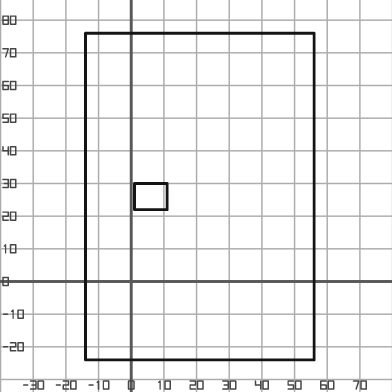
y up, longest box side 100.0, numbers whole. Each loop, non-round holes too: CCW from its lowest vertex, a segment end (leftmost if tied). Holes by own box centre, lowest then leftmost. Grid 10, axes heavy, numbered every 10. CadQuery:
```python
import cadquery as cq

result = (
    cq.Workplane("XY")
    .moveTo(-14.0, -24.0)
    .lineTo(56.0, -24.0)
    .lineTo(56.0, 76.0)
    .lineTo(-14.0, 76.0)
    .close()
    .moveTo(1.0, 22.0)
    .lineTo(11.0, 22.0)
    .lineTo(11.0, 30.0)
    .lineTo(1.0, 30.0)
    .close()
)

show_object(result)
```